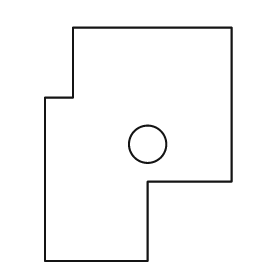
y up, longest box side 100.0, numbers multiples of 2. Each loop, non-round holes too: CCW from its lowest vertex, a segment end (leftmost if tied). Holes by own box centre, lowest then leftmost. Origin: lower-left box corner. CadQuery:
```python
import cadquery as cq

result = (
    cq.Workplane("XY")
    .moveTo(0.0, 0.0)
    .lineTo(44.0, 0.0)
    .lineTo(44.0, 34.0)
    .lineTo(80.0, 34.0)
    .lineTo(80.0, 100.0)
    .lineTo(12.0, 100.0)
    .lineTo(12.0, 70.0)
    .lineTo(0.0, 70.0)
    .close()
    .moveTo(44.0, 50.0)
    .circle(8.0)
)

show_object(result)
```